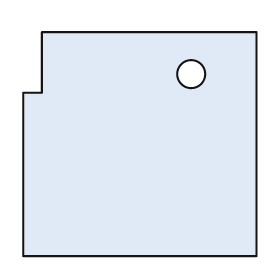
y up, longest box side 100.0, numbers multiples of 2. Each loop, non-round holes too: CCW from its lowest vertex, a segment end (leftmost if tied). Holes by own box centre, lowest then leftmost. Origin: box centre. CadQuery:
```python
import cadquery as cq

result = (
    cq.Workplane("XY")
    .moveTo(-50.0, -48.0)
    .lineTo(50.0, -48.0)
    .lineTo(50.0, 48.0)
    .lineTo(-42.0, 48.0)
    .lineTo(-42.0, 22.0)
    .lineTo(-50.0, 22.0)
    .close()
    .moveTo(22.0, 30.0)
    .circle(6.0)
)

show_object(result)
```